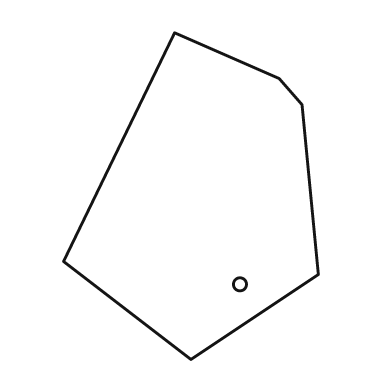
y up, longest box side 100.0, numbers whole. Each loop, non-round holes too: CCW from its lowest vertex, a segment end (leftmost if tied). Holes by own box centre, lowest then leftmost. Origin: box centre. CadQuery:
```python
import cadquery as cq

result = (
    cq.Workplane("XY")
    .moveTo(0.0, -50.0)
    .lineTo(39.0, -24.0)
    .lineTo(34.0, 28.0)
    .lineTo(27.0, 36.0)
    .lineTo(-5.0, 50.0)
    .lineTo(-39.0, -20.0)
    .close()
    .moveTo(15.0, -27.0)
    .circle(2.0)
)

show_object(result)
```